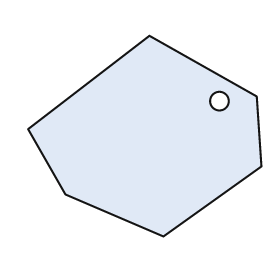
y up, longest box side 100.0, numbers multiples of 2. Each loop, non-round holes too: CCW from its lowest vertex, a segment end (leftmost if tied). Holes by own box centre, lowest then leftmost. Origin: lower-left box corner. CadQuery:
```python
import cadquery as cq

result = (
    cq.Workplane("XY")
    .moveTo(58.0, 0.0)
    .lineTo(100.0, 30.0)
    .lineTo(98.0, 60.0)
    .lineTo(52.0, 86.0)
    .lineTo(0.0, 46.0)
    .lineTo(16.0, 18.0)
    .close()
    .moveTo(82.0, 58.0)
    .circle(4.0)
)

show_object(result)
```